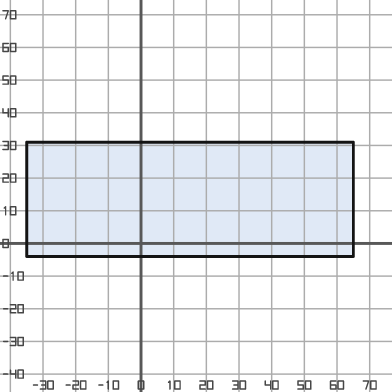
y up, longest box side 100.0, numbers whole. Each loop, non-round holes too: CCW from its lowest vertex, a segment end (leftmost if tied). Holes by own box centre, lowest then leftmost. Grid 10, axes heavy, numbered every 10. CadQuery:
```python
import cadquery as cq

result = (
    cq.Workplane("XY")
    .moveTo(-35.0, -4.0)
    .lineTo(65.0, -4.0)
    .lineTo(65.0, 31.0)
    .lineTo(-35.0, 31.0)
    .close()
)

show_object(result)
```